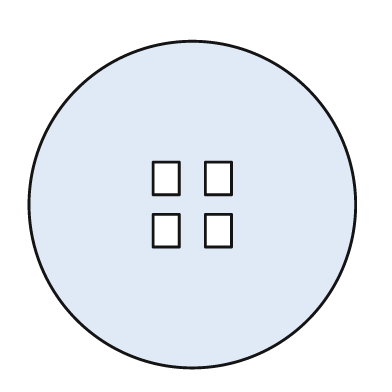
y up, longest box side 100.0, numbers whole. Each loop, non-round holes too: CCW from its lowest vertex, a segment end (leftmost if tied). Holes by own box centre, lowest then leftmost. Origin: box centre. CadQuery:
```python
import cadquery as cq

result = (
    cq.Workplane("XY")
    .moveTo(0.0, 0.0)
    .circle(50.0)
    .moveTo(-12.0, -13.0)
    .lineTo(-4.0, -13.0)
    .lineTo(-4.0, -3.0)
    .lineTo(-12.0, -3.0)
    .close()
    .moveTo(4.0, -13.0)
    .lineTo(12.0, -13.0)
    .lineTo(12.0, -3.0)
    .lineTo(4.0, -3.0)
    .close()
    .moveTo(-12.0, 3.0)
    .lineTo(-4.0, 3.0)
    .lineTo(-4.0, 13.0)
    .lineTo(-12.0, 13.0)
    .close()
    .moveTo(4.0, 3.0)
    .lineTo(12.0, 3.0)
    .lineTo(12.0, 13.0)
    .lineTo(4.0, 13.0)
    .close()
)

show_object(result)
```